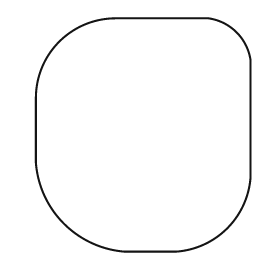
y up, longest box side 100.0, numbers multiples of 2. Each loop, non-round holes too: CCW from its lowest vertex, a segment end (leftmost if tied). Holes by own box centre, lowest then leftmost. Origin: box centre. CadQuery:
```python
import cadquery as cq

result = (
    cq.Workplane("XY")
    .moveTo(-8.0, -50.0)
    .lineTo(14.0, -50.0)
    .threePointArc((36.0, -40.0), (46.0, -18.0))
    .lineTo(46.0, 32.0)
    .threePointArc((40.0, 44.0), (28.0, 50.0))
    .lineTo(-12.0, 50.0)
    .threePointArc((-36.0, 40.0), (-46.0, 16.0))
    .lineTo(-46.0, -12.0)
    .threePointArc((-34.0, -38.0), (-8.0, -50.0))
    .close()
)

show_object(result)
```